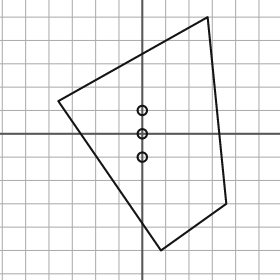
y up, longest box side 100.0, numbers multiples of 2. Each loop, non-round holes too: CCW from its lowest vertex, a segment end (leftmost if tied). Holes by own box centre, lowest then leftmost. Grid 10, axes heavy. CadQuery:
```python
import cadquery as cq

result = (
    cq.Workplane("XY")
    .moveTo(8.0, -50.0)
    .lineTo(36.0, -30.0)
    .lineTo(28.0, 50.0)
    .lineTo(-36.0, 14.0)
    .close()
    .moveTo(0.0, -10.0)
    .circle(2.0)
    .moveTo(0.0, 0.0)
    .circle(2.0)
    .moveTo(0.0, 10.0)
    .circle(2.0)
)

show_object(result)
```